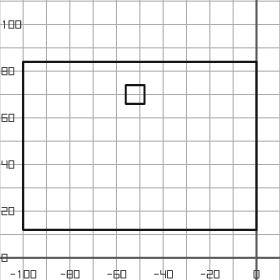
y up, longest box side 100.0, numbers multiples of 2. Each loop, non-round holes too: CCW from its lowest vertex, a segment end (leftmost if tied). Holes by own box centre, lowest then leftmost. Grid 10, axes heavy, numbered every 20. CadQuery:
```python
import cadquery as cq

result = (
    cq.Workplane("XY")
    .moveTo(-100.0, 12.0)
    .lineTo(0.0, 12.0)
    .lineTo(0.0, 84.0)
    .lineTo(-100.0, 84.0)
    .close()
    .moveTo(-56.0, 66.0)
    .lineTo(-48.0, 66.0)
    .lineTo(-48.0, 74.0)
    .lineTo(-56.0, 74.0)
    .close()
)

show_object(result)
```